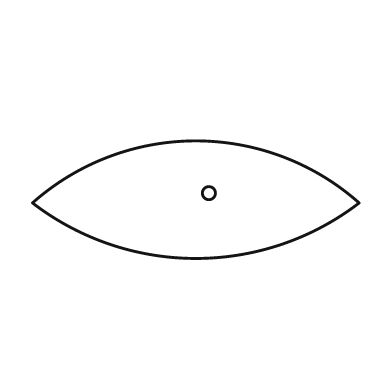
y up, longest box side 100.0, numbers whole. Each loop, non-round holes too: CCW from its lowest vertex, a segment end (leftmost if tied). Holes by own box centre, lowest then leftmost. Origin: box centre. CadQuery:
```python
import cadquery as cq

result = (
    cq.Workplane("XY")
    .moveTo(-50.0, -1.0)
    .threePointArc((0.0, -18.0), (50.0, -1.0))
    .threePointArc((0.0, 18.0), (-50.0, -1.0))
    .close()
    .moveTo(4.0, 2.0)
    .circle(2.0)
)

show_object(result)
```